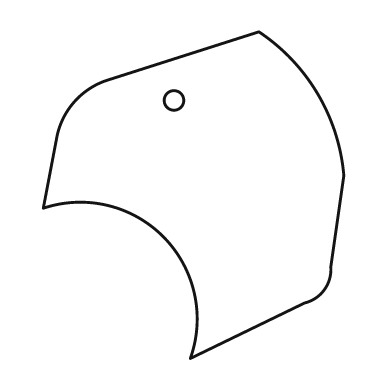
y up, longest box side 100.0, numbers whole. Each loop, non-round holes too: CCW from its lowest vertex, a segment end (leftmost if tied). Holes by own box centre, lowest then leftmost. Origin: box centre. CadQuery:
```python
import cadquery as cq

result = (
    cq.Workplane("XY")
    .moveTo(-1.0, -50.0)
    .lineTo(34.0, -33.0)
    .threePointArc((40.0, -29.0), (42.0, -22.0))
    .lineTo(46.0, 6.0)
    .threePointArc((38.0, 31.0), (20.0, 50.0))
    .lineTo(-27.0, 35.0)
    .threePointArc((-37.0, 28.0), (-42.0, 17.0))
    .lineTo(-46.0, -4.0)
    .threePointArc((-9.0, -13.0), (-1.0, -50.0))
    .close()
    .moveTo(-6.0, 29.0)
    .circle(3.0)
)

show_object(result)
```